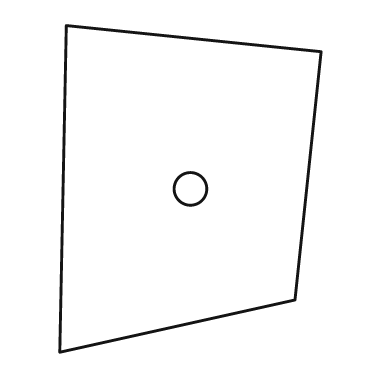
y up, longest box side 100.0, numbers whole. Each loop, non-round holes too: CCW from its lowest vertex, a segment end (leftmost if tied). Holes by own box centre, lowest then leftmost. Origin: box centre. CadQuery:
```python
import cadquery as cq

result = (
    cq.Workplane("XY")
    .moveTo(-40.0, -50.0)
    .lineTo(32.0, -34.0)
    .lineTo(40.0, 42.0)
    .lineTo(-38.0, 50.0)
    .close()
    .moveTo(0.0, 0.0)
    .circle(5.0)
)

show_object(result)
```